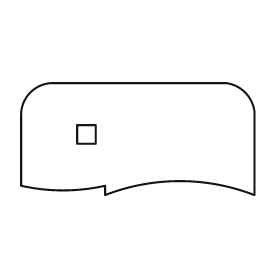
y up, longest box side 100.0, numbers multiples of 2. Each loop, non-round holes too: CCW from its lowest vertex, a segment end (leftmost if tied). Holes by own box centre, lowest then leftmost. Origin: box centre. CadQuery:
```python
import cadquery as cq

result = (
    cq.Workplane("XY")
    .moveTo(-14.0, -24.0)
    .threePointArc((18.0, -18.0), (50.0, -24.0))
    .lineTo(50.0, 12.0)
    .threePointArc((46.0, 20.0), (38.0, 24.0))
    .lineTo(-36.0, 24.0)
    .threePointArc((-46.0, 20.0), (-50.0, 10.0))
    .lineTo(-50.0, -20.0)
    .threePointArc((-32.0, -22.0), (-14.0, -20.0))
    .close()
    .moveTo(-26.0, -2.0)
    .lineTo(-18.0, -2.0)
    .lineTo(-18.0, 6.0)
    .lineTo(-26.0, 6.0)
    .close()
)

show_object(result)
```